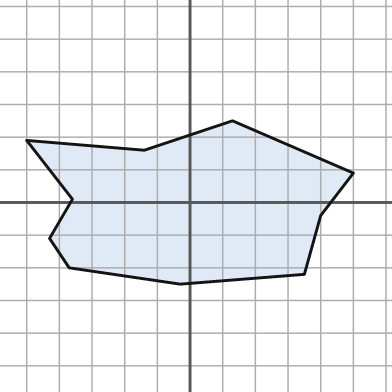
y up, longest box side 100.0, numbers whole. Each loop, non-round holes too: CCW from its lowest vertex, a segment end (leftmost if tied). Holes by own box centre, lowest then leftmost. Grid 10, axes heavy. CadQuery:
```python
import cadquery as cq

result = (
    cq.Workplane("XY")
    .moveTo(-3.0, -25.0)
    .lineTo(35.0, -22.0)
    .lineTo(40.0, -4.0)
    .lineTo(50.0, 9.0)
    .lineTo(13.0, 25.0)
    .lineTo(-14.0, 16.0)
    .lineTo(-50.0, 19.0)
    .lineTo(-36.0, 1.0)
    .lineTo(-43.0, -11.0)
    .lineTo(-37.0, -20.0)
    .close()
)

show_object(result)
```